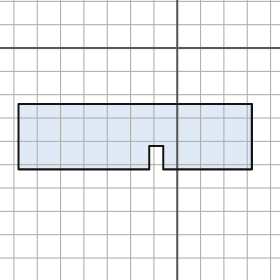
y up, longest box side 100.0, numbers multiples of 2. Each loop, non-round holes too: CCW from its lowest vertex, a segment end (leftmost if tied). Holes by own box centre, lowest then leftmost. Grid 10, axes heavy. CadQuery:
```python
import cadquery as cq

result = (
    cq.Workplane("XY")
    .moveTo(-68.0, -52.0)
    .lineTo(-12.0, -52.0)
    .lineTo(-12.0, -42.0)
    .lineTo(-6.0, -42.0)
    .lineTo(-6.0, -52.0)
    .lineTo(32.0, -52.0)
    .lineTo(32.0, -24.0)
    .lineTo(-68.0, -24.0)
    .close()
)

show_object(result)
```